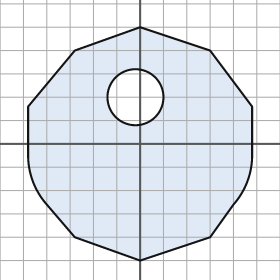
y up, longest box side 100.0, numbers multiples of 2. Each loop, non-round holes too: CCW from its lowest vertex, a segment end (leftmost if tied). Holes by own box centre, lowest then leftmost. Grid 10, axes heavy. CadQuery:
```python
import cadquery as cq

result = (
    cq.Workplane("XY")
    .moveTo(0.0, -50.0)
    .lineTo(30.0, -40.0)
    .lineTo(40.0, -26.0)
    .threePointArc((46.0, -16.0), (48.0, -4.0))
    .lineTo(48.0, 16.0)
    .lineTo(30.0, 40.0)
    .lineTo(0.0, 50.0)
    .lineTo(-28.0, 40.0)
    .lineTo(-48.0, 16.0)
    .lineTo(-48.0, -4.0)
    .threePointArc((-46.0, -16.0), (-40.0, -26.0))
    .lineTo(-28.0, -40.0)
    .close()
    .moveTo(-2.0, 20.0)
    .circle(12.0)
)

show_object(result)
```